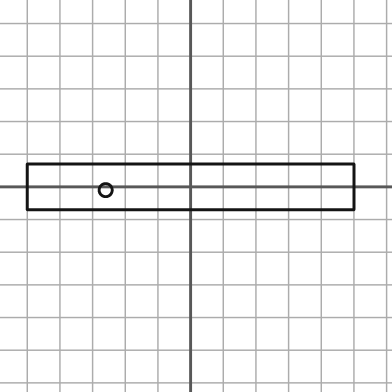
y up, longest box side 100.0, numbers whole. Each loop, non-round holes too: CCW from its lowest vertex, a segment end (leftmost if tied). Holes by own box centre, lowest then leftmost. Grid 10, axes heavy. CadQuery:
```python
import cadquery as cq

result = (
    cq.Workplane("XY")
    .moveTo(-50.0, -7.0)
    .lineTo(50.0, -7.0)
    .lineTo(50.0, 7.0)
    .lineTo(-50.0, 7.0)
    .close()
    .moveTo(-26.0, -1.0)
    .circle(2.0)
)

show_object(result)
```